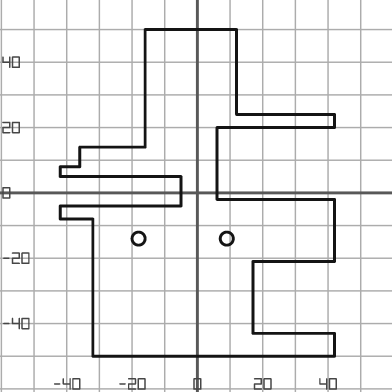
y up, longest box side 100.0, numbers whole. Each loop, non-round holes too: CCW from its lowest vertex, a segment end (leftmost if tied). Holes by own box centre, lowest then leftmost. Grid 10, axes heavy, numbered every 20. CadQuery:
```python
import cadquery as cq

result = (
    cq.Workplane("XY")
    .moveTo(-32.0, -50.0)
    .lineTo(42.0, -50.0)
    .lineTo(42.0, -43.0)
    .lineTo(17.0, -43.0)
    .lineTo(17.0, -21.0)
    .lineTo(42.0, -21.0)
    .lineTo(42.0, -2.0)
    .lineTo(6.0, -2.0)
    .lineTo(6.0, 20.0)
    .lineTo(42.0, 20.0)
    .lineTo(42.0, 24.0)
    .lineTo(12.0, 24.0)
    .lineTo(12.0, 50.0)
    .lineTo(-16.0, 50.0)
    .lineTo(-16.0, 14.0)
    .lineTo(-36.0, 14.0)
    .lineTo(-36.0, 8.0)
    .lineTo(-42.0, 8.0)
    .lineTo(-42.0, 5.0)
    .lineTo(-5.0, 5.0)
    .lineTo(-5.0, -4.0)
    .lineTo(-42.0, -4.0)
    .lineTo(-42.0, -8.0)
    .lineTo(-32.0, -8.0)
    .close()
    .moveTo(-18.0, -14.0)
    .circle(2.0)
    .moveTo(9.0, -14.0)
    .circle(2.0)
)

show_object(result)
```